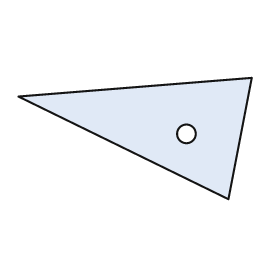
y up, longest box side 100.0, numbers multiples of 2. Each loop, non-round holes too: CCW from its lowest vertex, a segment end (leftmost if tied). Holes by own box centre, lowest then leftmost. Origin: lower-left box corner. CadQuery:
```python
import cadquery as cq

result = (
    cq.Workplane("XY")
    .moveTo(90.0, 0.0)
    .lineTo(100.0, 52.0)
    .lineTo(0.0, 44.0)
    .close()
    .moveTo(72.0, 28.0)
    .circle(4.0)
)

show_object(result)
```